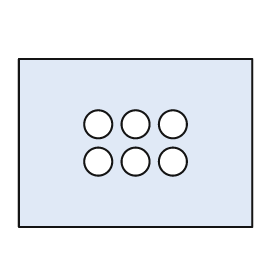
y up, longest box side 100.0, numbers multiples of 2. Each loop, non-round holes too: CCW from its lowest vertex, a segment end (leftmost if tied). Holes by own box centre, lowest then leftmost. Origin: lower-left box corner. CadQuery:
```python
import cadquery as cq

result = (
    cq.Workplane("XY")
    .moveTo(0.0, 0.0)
    .lineTo(100.0, 0.0)
    .lineTo(100.0, 72.0)
    .lineTo(0.0, 72.0)
    .close()
    .moveTo(34.0, 28.0)
    .circle(6.0)
    .moveTo(50.0, 28.0)
    .circle(6.0)
    .moveTo(66.0, 28.0)
    .circle(6.0)
    .moveTo(34.0, 44.0)
    .circle(6.0)
    .moveTo(50.0, 44.0)
    .circle(6.0)
    .moveTo(66.0, 44.0)
    .circle(6.0)
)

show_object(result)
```